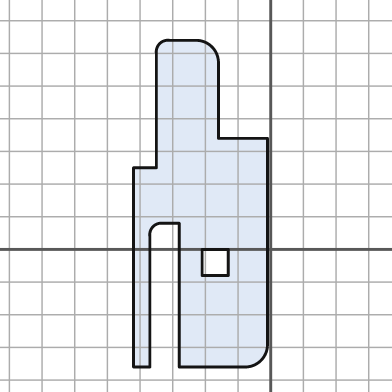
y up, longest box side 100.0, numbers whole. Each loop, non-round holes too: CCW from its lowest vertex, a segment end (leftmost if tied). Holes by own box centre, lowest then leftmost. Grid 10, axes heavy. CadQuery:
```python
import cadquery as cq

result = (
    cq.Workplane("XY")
    .moveTo(-42.0, -36.0)
    .lineTo(-37.0, -36.0)
    .lineTo(-37.0, 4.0)
    .threePointArc((-36.0, 7.0), (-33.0, 8.0))
    .lineTo(-28.0, 8.0)
    .lineTo(-28.0, -36.0)
    .lineTo(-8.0, -36.0)
    .threePointArc((-3.0, -34.0), (-1.0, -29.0))
    .lineTo(-1.0, 34.0)
    .lineTo(-16.0, 34.0)
    .lineTo(-16.0, 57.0)
    .threePointArc((-18.0, 62.0), (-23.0, 64.0))
    .lineTo(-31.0, 64.0)
    .threePointArc((-34.0, 63.0), (-35.0, 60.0))
    .lineTo(-35.0, 25.0)
    .lineTo(-42.0, 25.0)
    .close()
    .moveTo(-21.0, -8.0)
    .lineTo(-13.0, -8.0)
    .lineTo(-13.0, 0.0)
    .lineTo(-21.0, 0.0)
    .close()
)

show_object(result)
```